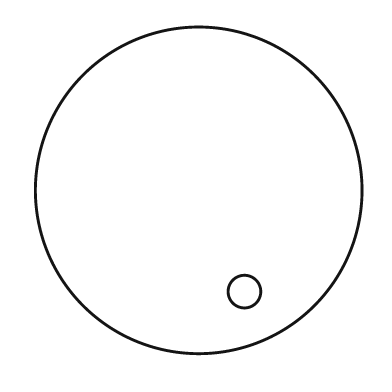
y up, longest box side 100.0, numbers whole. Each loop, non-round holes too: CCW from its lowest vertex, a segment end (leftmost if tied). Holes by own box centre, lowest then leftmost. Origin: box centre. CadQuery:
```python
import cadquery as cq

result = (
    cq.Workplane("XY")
    .moveTo(0.0, 0.0)
    .circle(50.0)
    .moveTo(14.0, -31.0)
    .circle(5.0)
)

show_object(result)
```